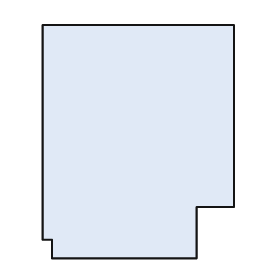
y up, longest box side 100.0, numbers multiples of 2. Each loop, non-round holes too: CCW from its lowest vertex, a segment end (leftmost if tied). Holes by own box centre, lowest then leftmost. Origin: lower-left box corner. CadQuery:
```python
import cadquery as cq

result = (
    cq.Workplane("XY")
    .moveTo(4.0, 0.0)
    .lineTo(66.0, 0.0)
    .lineTo(66.0, 22.0)
    .lineTo(82.0, 22.0)
    .lineTo(82.0, 100.0)
    .lineTo(0.0, 100.0)
    .lineTo(0.0, 8.0)
    .lineTo(4.0, 8.0)
    .close()
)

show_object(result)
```